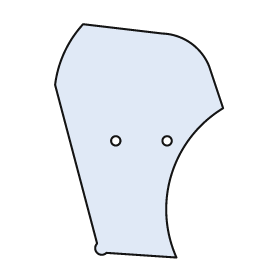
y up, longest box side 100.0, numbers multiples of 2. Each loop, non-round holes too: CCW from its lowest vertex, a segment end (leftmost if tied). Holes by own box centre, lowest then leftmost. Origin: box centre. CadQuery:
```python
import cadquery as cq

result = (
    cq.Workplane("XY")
    .moveTo(16.0, -50.0)
    .threePointArc((14.0, -14.0), (36.0, 14.0))
    .lineTo(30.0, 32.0)
    .threePointArc((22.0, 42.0), (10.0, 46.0))
    .lineTo(-24.0, 50.0)
    .threePointArc((-32.0, 38.0), (-36.0, 24.0))
    .lineTo(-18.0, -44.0)
    .threePointArc((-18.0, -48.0), (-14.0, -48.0))
    .close()
    .moveTo(-10.0, 0.0)
    .circle(2.0)
    .moveTo(12.0, 0.0)
    .circle(2.0)
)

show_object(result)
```